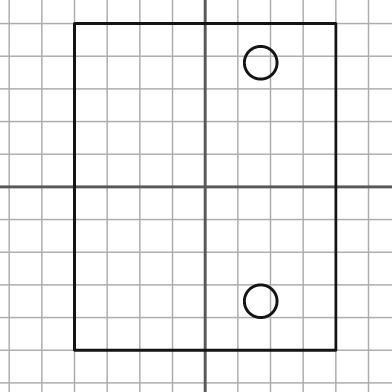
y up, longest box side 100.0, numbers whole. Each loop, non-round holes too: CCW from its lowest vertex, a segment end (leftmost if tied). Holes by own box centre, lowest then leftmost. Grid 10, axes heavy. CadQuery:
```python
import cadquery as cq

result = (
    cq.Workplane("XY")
    .moveTo(-40.0, -50.0)
    .lineTo(40.0, -50.0)
    .lineTo(40.0, 50.0)
    .lineTo(-40.0, 50.0)
    .close()
    .moveTo(17.0, -35.0)
    .circle(5.0)
    .moveTo(17.0, 38.0)
    .circle(5.0)
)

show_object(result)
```